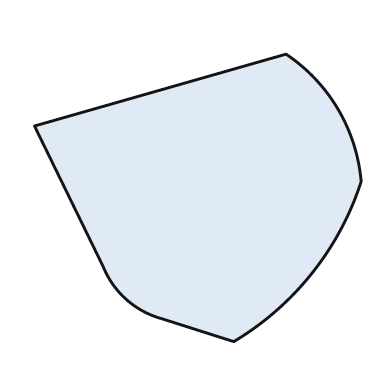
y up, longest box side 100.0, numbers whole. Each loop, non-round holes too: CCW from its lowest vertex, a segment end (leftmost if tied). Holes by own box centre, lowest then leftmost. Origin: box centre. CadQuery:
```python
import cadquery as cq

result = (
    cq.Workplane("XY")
    .moveTo(11.0, -44.0)
    .threePointArc((35.0, -23.0), (50.0, 5.0))
    .threePointArc((43.0, 27.0), (27.0, 44.0))
    .lineTo(-50.0, 22.0)
    .lineTo(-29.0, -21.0)
    .threePointArc((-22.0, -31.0), (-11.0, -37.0))
    .close()
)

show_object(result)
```